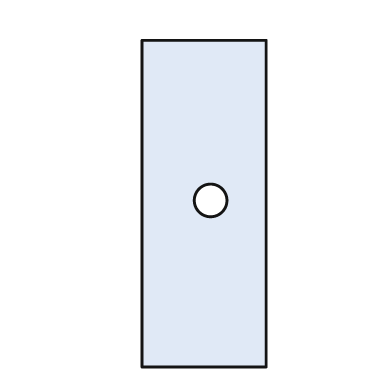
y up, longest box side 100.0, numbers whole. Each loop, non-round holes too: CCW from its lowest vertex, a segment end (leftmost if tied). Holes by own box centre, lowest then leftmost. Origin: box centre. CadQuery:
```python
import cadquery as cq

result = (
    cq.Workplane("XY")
    .moveTo(-19.0, -50.0)
    .lineTo(19.0, -50.0)
    .lineTo(19.0, 50.0)
    .lineTo(-19.0, 50.0)
    .close()
    .moveTo(2.0, 1.0)
    .circle(5.0)
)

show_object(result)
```